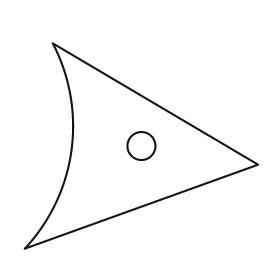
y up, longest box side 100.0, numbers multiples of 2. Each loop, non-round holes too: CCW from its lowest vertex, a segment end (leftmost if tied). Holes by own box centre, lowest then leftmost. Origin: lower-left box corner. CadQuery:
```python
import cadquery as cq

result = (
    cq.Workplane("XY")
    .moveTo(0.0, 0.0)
    .lineTo(100.0, 36.0)
    .lineTo(12.0, 88.0)
    .threePointArc((20.0, 42.0), (0.0, 0.0))
    .close()
    .moveTo(50.0, 44.0)
    .circle(6.0)
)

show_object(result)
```